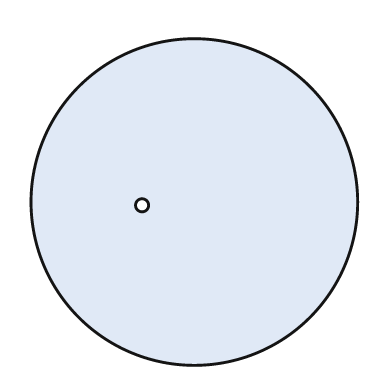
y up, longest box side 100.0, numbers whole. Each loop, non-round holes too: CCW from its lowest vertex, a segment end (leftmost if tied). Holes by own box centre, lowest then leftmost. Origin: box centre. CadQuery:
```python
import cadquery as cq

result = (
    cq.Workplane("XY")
    .moveTo(0.0, 0.0)
    .circle(50.0)
    .moveTo(-16.0, -1.0)
    .circle(2.0)
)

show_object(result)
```